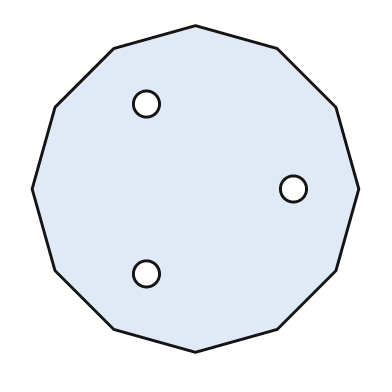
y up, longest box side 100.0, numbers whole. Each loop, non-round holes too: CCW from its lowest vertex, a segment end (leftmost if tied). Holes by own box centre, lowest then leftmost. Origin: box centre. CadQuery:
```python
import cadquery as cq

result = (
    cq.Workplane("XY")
    .moveTo(0.0, -50.0)
    .lineTo(25.0, -43.0)
    .lineTo(43.0, -25.0)
    .lineTo(50.0, 0.0)
    .lineTo(43.0, 25.0)
    .lineTo(25.0, 43.0)
    .lineTo(0.0, 50.0)
    .lineTo(-25.0, 43.0)
    .lineTo(-43.0, 25.0)
    .lineTo(-50.0, 0.0)
    .lineTo(-43.0, -25.0)
    .lineTo(-25.0, -43.0)
    .close()
    .moveTo(-15.0, -26.0)
    .circle(4.0)
    .moveTo(30.0, 0.0)
    .circle(4.0)
    .moveTo(-15.0, 26.0)
    .circle(4.0)
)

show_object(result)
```